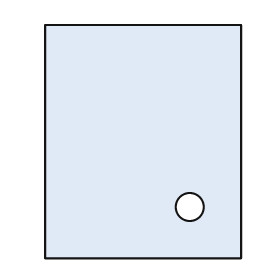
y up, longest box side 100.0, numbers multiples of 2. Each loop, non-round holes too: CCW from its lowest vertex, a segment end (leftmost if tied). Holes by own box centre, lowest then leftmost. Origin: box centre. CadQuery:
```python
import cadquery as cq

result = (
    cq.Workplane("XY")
    .moveTo(-42.0, -50.0)
    .lineTo(42.0, -50.0)
    .lineTo(42.0, 50.0)
    .lineTo(-42.0, 50.0)
    .close()
    .moveTo(20.0, -28.0)
    .circle(6.0)
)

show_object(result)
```